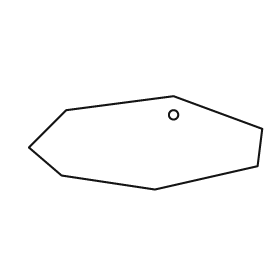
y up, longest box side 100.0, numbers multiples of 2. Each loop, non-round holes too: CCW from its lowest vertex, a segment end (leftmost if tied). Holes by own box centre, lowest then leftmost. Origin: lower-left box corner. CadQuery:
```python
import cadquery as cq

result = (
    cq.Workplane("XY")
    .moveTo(54.0, 0.0)
    .lineTo(98.0, 10.0)
    .lineTo(100.0, 26.0)
    .lineTo(62.0, 40.0)
    .lineTo(16.0, 34.0)
    .lineTo(0.0, 18.0)
    .lineTo(14.0, 6.0)
    .close()
    .moveTo(62.0, 32.0)
    .circle(2.0)
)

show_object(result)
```